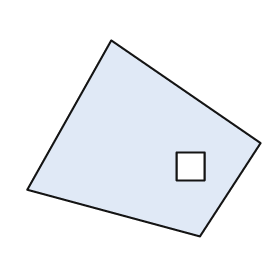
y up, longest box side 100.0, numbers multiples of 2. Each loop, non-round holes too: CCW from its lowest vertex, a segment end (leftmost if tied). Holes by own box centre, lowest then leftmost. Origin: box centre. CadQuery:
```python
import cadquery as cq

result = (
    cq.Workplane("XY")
    .moveTo(24.0, -42.0)
    .lineTo(50.0, -2.0)
    .lineTo(-14.0, 42.0)
    .lineTo(-50.0, -22.0)
    .close()
    .moveTo(14.0, -18.0)
    .lineTo(26.0, -18.0)
    .lineTo(26.0, -6.0)
    .lineTo(14.0, -6.0)
    .close()
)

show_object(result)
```